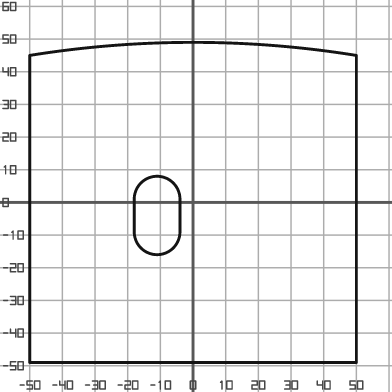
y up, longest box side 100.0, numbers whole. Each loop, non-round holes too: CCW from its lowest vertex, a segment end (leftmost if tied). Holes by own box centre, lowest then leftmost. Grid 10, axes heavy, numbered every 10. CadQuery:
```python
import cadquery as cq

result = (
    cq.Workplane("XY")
    .moveTo(-50.0, -49.0)
    .lineTo(50.0, -49.0)
    .lineTo(50.0, 45.0)
    .threePointArc((0.0, 49.0), (-50.0, 45.0))
    .close()
    .moveTo(-18.0, -9.0)
    .threePointArc((-11.0, -16.0), (-4.0, -9.0))
    .lineTo(-4.0, 1.0)
    .threePointArc((-11.0, 8.0), (-18.0, 1.0))
    .close()
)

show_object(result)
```